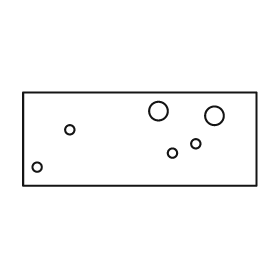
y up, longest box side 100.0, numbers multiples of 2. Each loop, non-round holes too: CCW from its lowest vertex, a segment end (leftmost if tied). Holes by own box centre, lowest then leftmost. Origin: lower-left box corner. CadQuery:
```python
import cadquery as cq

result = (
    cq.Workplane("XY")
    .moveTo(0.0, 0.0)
    .lineTo(100.0, 0.0)
    .lineTo(100.0, 40.0)
    .lineTo(0.0, 40.0)
    .close()
    .moveTo(6.0, 8.0)
    .circle(2.0)
    .moveTo(64.0, 14.0)
    .circle(2.0)
    .moveTo(74.0, 18.0)
    .circle(2.0)
    .moveTo(20.0, 24.0)
    .circle(2.0)
    .moveTo(82.0, 30.0)
    .circle(4.0)
    .moveTo(58.0, 32.0)
    .circle(4.0)
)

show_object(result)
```